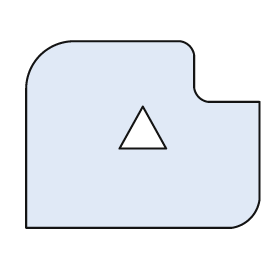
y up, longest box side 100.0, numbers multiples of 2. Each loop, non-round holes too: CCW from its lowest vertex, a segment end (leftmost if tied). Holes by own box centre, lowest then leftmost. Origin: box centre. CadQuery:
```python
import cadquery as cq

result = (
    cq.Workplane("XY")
    .moveTo(-50.0, -40.0)
    .lineTo(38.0, -40.0)
    .threePointArc((46.0, -36.0), (50.0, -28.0))
    .lineTo(50.0, 14.0)
    .lineTo(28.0, 14.0)
    .threePointArc((24.0, 16.0), (22.0, 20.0))
    .lineTo(22.0, 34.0)
    .threePointArc((20.0, 38.0), (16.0, 40.0))
    .lineTo(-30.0, 40.0)
    .threePointArc((-44.0, 34.0), (-50.0, 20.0))
    .close()
    .moveTo(-10.0, -6.0)
    .lineTo(10.0, -6.0)
    .lineTo(0.0, 12.0)
    .close()
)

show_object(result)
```